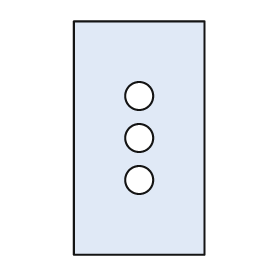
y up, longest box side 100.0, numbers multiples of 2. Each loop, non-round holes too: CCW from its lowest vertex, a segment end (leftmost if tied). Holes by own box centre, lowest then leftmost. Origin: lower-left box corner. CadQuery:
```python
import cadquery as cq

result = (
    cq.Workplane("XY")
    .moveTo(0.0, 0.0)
    .lineTo(56.0, 0.0)
    .lineTo(56.0, 100.0)
    .lineTo(0.0, 100.0)
    .close()
    .moveTo(28.0, 32.0)
    .circle(6.0)
    .moveTo(28.0, 50.0)
    .circle(6.0)
    .moveTo(28.0, 68.0)
    .circle(6.0)
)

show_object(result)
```